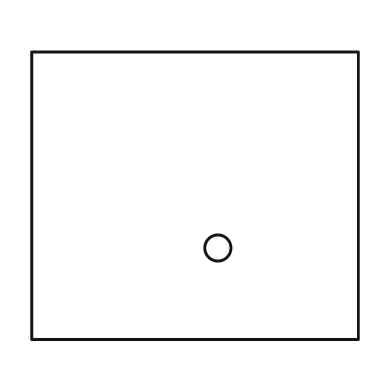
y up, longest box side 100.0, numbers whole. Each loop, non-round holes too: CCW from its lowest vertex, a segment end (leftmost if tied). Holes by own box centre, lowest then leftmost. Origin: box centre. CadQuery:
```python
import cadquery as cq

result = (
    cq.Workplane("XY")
    .moveTo(-50.0, -44.0)
    .lineTo(50.0, -44.0)
    .lineTo(50.0, 44.0)
    .lineTo(-50.0, 44.0)
    .close()
    .moveTo(7.0, -16.0)
    .circle(4.0)
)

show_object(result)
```